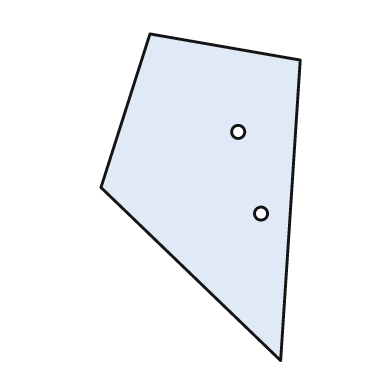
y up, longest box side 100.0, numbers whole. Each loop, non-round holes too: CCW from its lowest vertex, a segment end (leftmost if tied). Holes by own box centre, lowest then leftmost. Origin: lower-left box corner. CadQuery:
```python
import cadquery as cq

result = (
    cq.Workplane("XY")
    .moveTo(55.0, 0.0)
    .lineTo(61.0, 92.0)
    .lineTo(15.0, 100.0)
    .lineTo(0.0, 53.0)
    .close()
    .moveTo(49.0, 45.0)
    .circle(2.0)
    .moveTo(42.0, 70.0)
    .circle(2.0)
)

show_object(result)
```